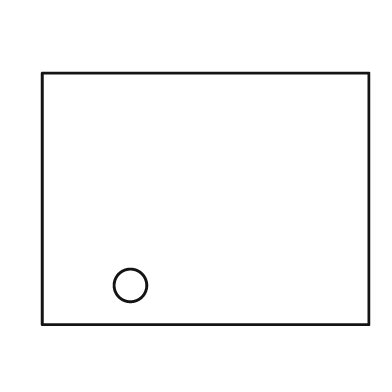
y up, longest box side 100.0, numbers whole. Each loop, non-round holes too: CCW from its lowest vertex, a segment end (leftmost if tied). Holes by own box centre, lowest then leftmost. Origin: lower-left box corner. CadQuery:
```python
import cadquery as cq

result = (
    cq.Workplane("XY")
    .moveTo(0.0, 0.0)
    .lineTo(100.0, 0.0)
    .lineTo(100.0, 77.0)
    .lineTo(0.0, 77.0)
    .close()
    .moveTo(27.0, 12.0)
    .circle(5.0)
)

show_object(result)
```